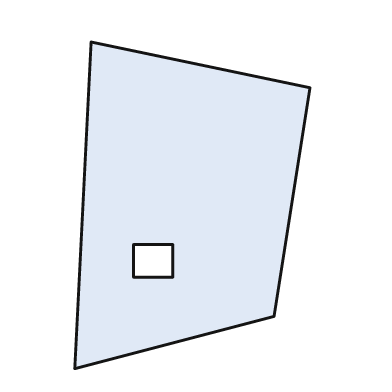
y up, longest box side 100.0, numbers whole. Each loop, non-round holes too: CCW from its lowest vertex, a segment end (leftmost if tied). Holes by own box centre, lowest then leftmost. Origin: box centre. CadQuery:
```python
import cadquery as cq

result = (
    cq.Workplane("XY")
    .moveTo(-36.0, -50.0)
    .lineTo(25.0, -34.0)
    .lineTo(36.0, 36.0)
    .lineTo(-31.0, 50.0)
    .close()
    .moveTo(-18.0, -22.0)
    .lineTo(-6.0, -22.0)
    .lineTo(-6.0, -12.0)
    .lineTo(-18.0, -12.0)
    .close()
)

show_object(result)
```